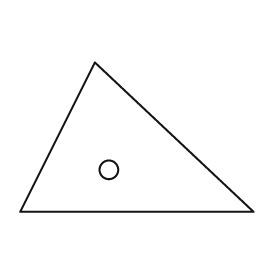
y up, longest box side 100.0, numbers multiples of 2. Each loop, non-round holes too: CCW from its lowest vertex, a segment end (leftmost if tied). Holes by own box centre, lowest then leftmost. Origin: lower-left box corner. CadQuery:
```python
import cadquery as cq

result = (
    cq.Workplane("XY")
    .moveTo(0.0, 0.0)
    .lineTo(100.0, 0.0)
    .lineTo(32.0, 64.0)
    .close()
    .moveTo(38.0, 18.0)
    .circle(4.0)
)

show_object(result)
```